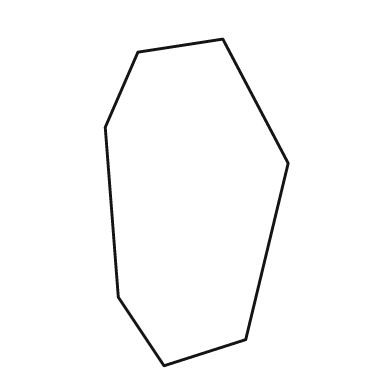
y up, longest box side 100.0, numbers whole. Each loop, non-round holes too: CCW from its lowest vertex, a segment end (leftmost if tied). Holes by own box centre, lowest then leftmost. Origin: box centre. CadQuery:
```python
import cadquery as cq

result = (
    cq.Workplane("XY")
    .moveTo(-10.0, -50.0)
    .lineTo(15.0, -42.0)
    .lineTo(28.0, 12.0)
    .lineTo(8.0, 50.0)
    .lineTo(-18.0, 46.0)
    .lineTo(-28.0, 23.0)
    .lineTo(-24.0, -29.0)
    .close()
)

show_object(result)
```